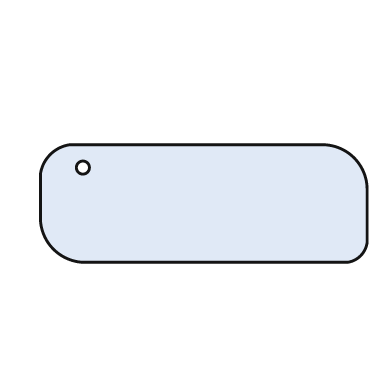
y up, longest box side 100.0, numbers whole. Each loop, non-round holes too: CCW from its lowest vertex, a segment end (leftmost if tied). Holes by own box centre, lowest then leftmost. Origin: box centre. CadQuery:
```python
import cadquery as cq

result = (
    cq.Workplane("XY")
    .moveTo(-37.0, -18.0)
    .lineTo(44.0, -18.0)
    .threePointArc((48.0, -16.0), (50.0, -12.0))
    .lineTo(50.0, 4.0)
    .threePointArc((46.0, 14.0), (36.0, 18.0))
    .lineTo(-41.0, 18.0)
    .threePointArc((-47.0, 15.0), (-50.0, 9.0))
    .lineTo(-50.0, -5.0)
    .threePointArc((-46.0, -14.0), (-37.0, -18.0))
    .close()
    .moveTo(-37.0, 11.0)
    .circle(2.0)
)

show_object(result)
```